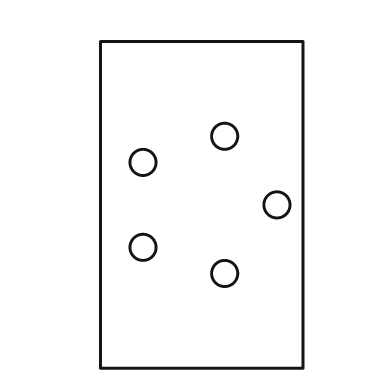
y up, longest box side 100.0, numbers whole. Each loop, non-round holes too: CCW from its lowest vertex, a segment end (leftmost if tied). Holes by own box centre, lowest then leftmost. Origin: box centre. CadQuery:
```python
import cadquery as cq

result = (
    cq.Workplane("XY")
    .moveTo(-31.0, -50.0)
    .lineTo(31.0, -50.0)
    .lineTo(31.0, 50.0)
    .lineTo(-31.0, 50.0)
    .close()
    .moveTo(7.0, -21.0)
    .circle(4.0)
    .moveTo(-18.0, -13.0)
    .circle(4.0)
    .moveTo(23.0, 0.0)
    .circle(4.0)
    .moveTo(-18.0, 13.0)
    .circle(4.0)
    .moveTo(7.0, 21.0)
    .circle(4.0)
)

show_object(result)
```